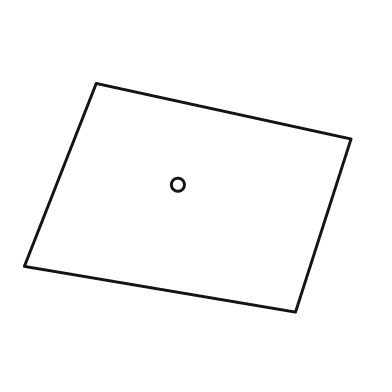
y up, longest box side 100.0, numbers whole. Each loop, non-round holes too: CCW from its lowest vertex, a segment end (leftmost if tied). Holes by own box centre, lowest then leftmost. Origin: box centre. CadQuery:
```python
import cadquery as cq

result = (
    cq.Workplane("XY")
    .moveTo(33.0, -35.0)
    .lineTo(50.0, 18.0)
    .lineTo(-28.0, 35.0)
    .lineTo(-50.0, -21.0)
    .close()
    .moveTo(-3.0, 4.0)
    .circle(2.0)
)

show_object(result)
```